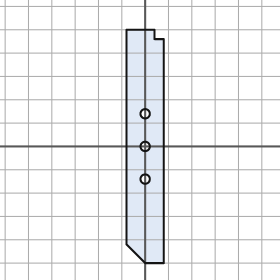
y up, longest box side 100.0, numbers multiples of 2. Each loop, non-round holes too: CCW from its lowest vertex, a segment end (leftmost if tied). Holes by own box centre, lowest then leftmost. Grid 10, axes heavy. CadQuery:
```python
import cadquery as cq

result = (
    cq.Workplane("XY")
    .moveTo(0.0, -50.0)
    .lineTo(8.0, -50.0)
    .lineTo(8.0, 46.0)
    .lineTo(4.0, 46.0)
    .lineTo(4.0, 50.0)
    .lineTo(-8.0, 50.0)
    .lineTo(-8.0, -42.0)
    .close()
    .moveTo(0.0, -14.0)
    .circle(2.0)
    .moveTo(0.0, 0.0)
    .circle(2.0)
    .moveTo(0.0, 14.0)
    .circle(2.0)
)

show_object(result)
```